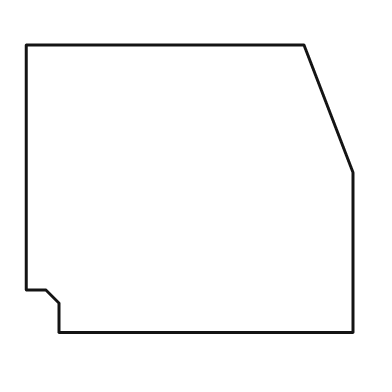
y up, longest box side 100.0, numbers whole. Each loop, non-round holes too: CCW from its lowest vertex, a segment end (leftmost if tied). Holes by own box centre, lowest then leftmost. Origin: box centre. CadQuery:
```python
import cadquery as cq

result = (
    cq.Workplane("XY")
    .moveTo(-40.0, -44.0)
    .lineTo(50.0, -44.0)
    .lineTo(50.0, 5.0)
    .lineTo(35.0, 44.0)
    .lineTo(-50.0, 44.0)
    .lineTo(-50.0, -31.0)
    .lineTo(-44.0, -31.0)
    .lineTo(-40.0, -35.0)
    .close()
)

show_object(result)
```